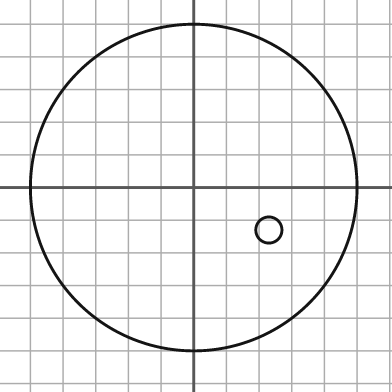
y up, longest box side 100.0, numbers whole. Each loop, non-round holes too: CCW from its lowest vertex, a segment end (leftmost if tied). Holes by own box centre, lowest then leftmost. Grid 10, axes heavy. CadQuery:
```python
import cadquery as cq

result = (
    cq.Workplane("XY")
    .moveTo(0.0, 0.0)
    .circle(50.0)
    .moveTo(23.0, -13.0)
    .circle(4.0)
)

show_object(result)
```